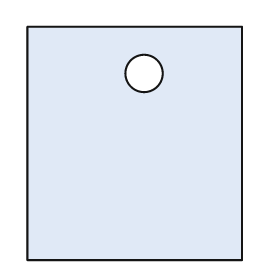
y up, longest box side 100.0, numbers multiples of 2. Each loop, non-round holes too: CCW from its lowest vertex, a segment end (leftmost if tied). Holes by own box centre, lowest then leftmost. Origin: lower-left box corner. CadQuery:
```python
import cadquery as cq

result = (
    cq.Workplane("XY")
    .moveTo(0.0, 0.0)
    .lineTo(92.0, 0.0)
    .lineTo(92.0, 100.0)
    .lineTo(0.0, 100.0)
    .close()
    .moveTo(50.0, 80.0)
    .circle(8.0)
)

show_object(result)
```